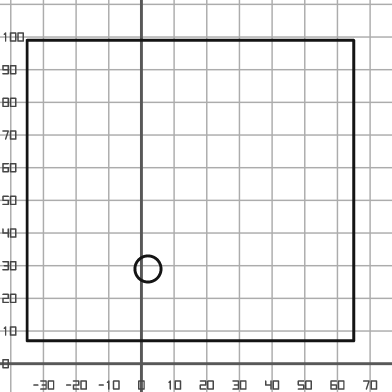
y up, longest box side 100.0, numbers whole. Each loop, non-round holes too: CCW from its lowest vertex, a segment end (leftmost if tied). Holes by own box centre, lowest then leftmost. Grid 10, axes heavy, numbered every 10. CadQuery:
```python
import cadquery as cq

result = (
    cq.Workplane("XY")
    .moveTo(-35.0, 7.0)
    .lineTo(65.0, 7.0)
    .lineTo(65.0, 99.0)
    .lineTo(-35.0, 99.0)
    .close()
    .moveTo(2.0, 29.0)
    .circle(4.0)
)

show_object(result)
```